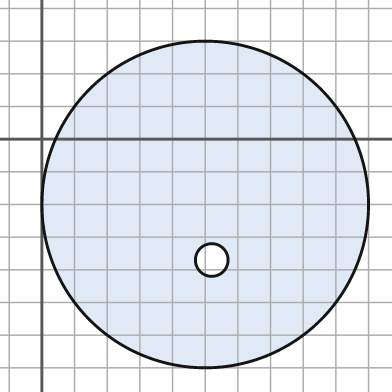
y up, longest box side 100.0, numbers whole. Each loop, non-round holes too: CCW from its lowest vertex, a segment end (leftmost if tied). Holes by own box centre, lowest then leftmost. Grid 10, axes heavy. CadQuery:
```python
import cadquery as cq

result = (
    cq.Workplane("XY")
    .moveTo(50.0, -20.0)
    .circle(50.0)
    .moveTo(52.0, -37.0)
    .circle(5.0)
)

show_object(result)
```